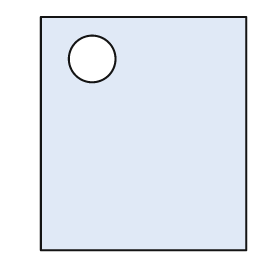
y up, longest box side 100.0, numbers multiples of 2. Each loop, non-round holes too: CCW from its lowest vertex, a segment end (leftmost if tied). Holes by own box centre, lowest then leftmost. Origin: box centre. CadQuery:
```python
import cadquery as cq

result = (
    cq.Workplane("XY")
    .moveTo(-44.0, -50.0)
    .lineTo(44.0, -50.0)
    .lineTo(44.0, 50.0)
    .lineTo(-44.0, 50.0)
    .close()
    .moveTo(-22.0, 32.0)
    .circle(10.0)
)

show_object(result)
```